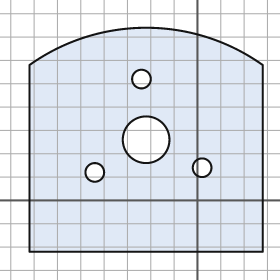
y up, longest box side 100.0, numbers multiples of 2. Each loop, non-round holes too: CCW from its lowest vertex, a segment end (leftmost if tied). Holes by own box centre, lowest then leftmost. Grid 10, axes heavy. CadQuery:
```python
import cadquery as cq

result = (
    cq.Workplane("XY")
    .moveTo(-72.0, -22.0)
    .lineTo(28.0, -22.0)
    .lineTo(28.0, 58.0)
    .threePointArc((-22.0, 74.0), (-72.0, 58.0))
    .close()
    .moveTo(-44.0, 12.0)
    .circle(4.0)
    .moveTo(2.0, 14.0)
    .circle(4.0)
    .moveTo(-22.0, 26.0)
    .circle(10.0)
    .moveTo(-24.0, 52.0)
    .circle(4.0)
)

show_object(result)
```